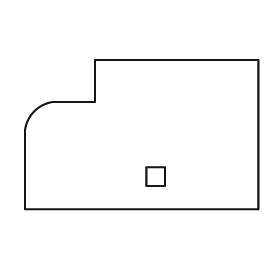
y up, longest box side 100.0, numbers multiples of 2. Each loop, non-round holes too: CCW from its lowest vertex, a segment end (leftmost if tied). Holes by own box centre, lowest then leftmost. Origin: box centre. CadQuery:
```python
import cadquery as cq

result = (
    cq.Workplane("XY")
    .moveTo(-50.0, -32.0)
    .lineTo(50.0, -32.0)
    .lineTo(50.0, 32.0)
    .lineTo(-20.0, 32.0)
    .lineTo(-20.0, 14.0)
    .lineTo(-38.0, 14.0)
    .threePointArc((-46.0, 10.0), (-50.0, 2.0))
    .close()
    .moveTo(2.0, -22.0)
    .lineTo(10.0, -22.0)
    .lineTo(10.0, -14.0)
    .lineTo(2.0, -14.0)
    .close()
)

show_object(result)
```